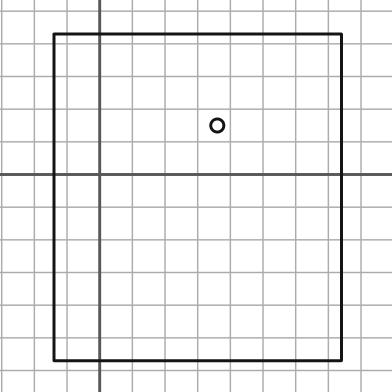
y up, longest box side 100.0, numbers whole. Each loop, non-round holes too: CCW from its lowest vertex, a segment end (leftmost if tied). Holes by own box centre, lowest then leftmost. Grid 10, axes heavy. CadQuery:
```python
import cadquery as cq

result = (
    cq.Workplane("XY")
    .moveTo(-14.0, -57.0)
    .lineTo(74.0, -57.0)
    .lineTo(74.0, 43.0)
    .lineTo(-14.0, 43.0)
    .close()
    .moveTo(36.0, 15.0)
    .circle(2.0)
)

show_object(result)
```